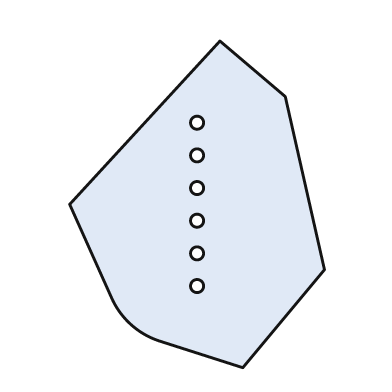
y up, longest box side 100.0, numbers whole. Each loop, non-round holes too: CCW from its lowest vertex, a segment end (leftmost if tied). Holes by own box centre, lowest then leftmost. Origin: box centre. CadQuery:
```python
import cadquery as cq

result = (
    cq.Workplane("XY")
    .moveTo(14.0, -50.0)
    .lineTo(39.0, -20.0)
    .lineTo(27.0, 33.0)
    .lineTo(7.0, 50.0)
    .lineTo(-39.0, 0.0)
    .lineTo(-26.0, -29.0)
    .threePointArc((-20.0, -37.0), (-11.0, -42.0))
    .close()
    .moveTo(0.0, -25.0)
    .circle(2.0)
    .moveTo(0.0, -15.0)
    .circle(2.0)
    .moveTo(0.0, -5.0)
    .circle(2.0)
    .moveTo(0.0, 5.0)
    .circle(2.0)
    .moveTo(0.0, 15.0)
    .circle(2.0)
    .moveTo(0.0, 25.0)
    .circle(2.0)
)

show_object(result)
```